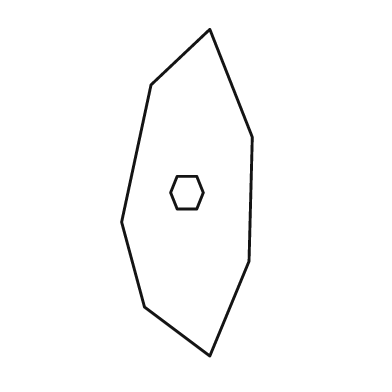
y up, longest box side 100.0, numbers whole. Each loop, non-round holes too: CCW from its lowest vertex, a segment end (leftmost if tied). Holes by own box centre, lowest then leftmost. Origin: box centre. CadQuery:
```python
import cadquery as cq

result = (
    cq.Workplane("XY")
    .moveTo(7.0, -50.0)
    .lineTo(19.0, -21.0)
    .lineTo(20.0, 17.0)
    .lineTo(7.0, 50.0)
    .lineTo(-11.0, 33.0)
    .lineTo(-20.0, -9.0)
    .lineTo(-13.0, -35.0)
    .close()
    .moveTo(-3.0, -5.0)
    .lineTo(3.0, -5.0)
    .lineTo(5.0, 0.0)
    .lineTo(3.0, 5.0)
    .lineTo(-3.0, 5.0)
    .lineTo(-5.0, 0.0)
    .close()
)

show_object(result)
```